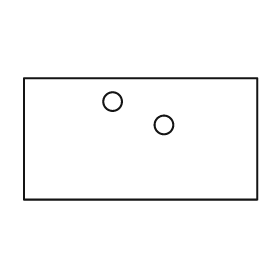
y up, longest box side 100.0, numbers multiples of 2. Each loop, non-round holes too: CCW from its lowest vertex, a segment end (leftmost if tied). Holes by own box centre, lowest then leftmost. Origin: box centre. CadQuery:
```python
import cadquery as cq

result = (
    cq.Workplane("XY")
    .moveTo(-50.0, -26.0)
    .lineTo(50.0, -26.0)
    .lineTo(50.0, 26.0)
    .lineTo(-50.0, 26.0)
    .close()
    .moveTo(10.0, 6.0)
    .circle(4.0)
    .moveTo(-12.0, 16.0)
    .circle(4.0)
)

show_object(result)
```